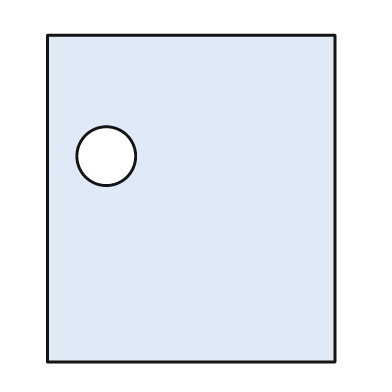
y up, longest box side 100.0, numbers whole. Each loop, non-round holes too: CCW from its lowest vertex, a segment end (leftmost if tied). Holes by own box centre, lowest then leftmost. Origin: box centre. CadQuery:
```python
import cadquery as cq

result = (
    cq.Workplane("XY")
    .moveTo(-44.0, -50.0)
    .lineTo(44.0, -50.0)
    .lineTo(44.0, 50.0)
    .lineTo(-44.0, 50.0)
    .close()
    .moveTo(-26.0, 13.0)
    .circle(9.0)
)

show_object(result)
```